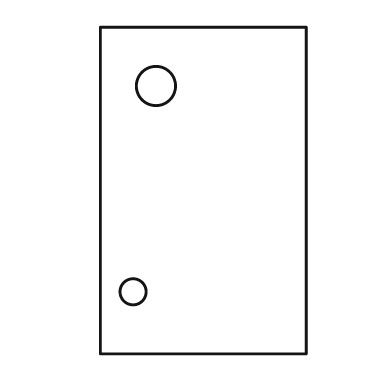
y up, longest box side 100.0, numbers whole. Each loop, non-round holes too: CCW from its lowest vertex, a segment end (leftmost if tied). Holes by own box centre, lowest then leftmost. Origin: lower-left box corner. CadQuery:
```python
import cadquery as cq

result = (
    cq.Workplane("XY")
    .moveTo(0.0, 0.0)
    .lineTo(63.0, 0.0)
    .lineTo(63.0, 100.0)
    .lineTo(0.0, 100.0)
    .close()
    .moveTo(10.0, 19.0)
    .circle(4.0)
    .moveTo(17.0, 82.0)
    .circle(6.0)
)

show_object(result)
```